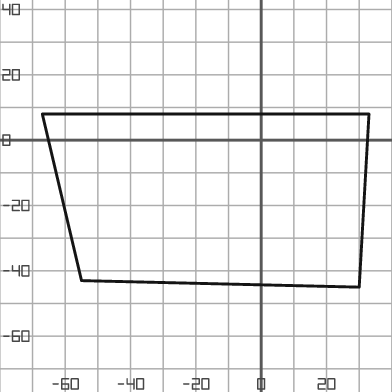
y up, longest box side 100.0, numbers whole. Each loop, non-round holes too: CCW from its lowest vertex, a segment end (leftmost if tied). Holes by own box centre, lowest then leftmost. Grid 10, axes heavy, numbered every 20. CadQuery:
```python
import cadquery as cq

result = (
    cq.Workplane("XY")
    .moveTo(30.0, -45.0)
    .lineTo(33.0, 8.0)
    .lineTo(-67.0, 8.0)
    .lineTo(-55.0, -43.0)
    .close()
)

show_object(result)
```